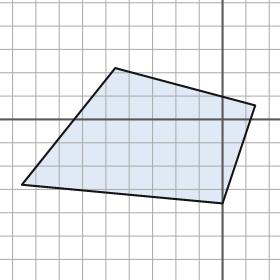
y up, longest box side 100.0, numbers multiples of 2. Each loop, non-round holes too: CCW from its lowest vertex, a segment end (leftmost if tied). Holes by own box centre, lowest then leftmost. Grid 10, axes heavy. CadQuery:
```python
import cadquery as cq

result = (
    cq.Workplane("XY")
    .moveTo(0.0, -36.0)
    .lineTo(14.0, 6.0)
    .lineTo(-46.0, 22.0)
    .lineTo(-86.0, -28.0)
    .close()
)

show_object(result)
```